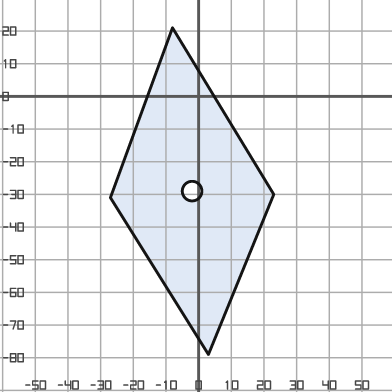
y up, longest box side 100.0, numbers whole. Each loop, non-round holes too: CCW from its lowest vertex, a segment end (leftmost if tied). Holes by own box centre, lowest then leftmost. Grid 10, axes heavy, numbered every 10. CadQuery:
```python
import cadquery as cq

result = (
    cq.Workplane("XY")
    .moveTo(3.0, -79.0)
    .lineTo(23.0, -30.0)
    .lineTo(-8.0, 21.0)
    .lineTo(-27.0, -31.0)
    .close()
    .moveTo(-2.0, -29.0)
    .circle(3.0)
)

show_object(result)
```